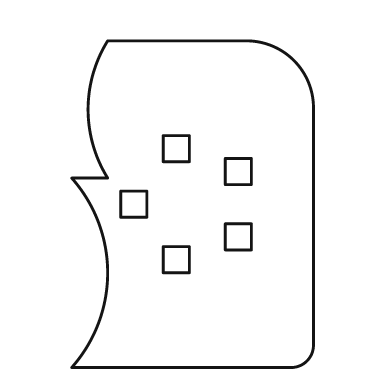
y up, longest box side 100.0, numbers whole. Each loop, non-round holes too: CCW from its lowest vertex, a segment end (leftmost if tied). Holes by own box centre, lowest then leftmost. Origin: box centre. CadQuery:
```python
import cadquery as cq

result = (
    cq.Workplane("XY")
    .moveTo(-37.0, -50.0)
    .lineTo(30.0, -50.0)
    .threePointArc((35.0, -48.0), (37.0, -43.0))
    .lineTo(37.0, 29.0)
    .threePointArc((31.0, 44.0), (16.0, 50.0))
    .lineTo(-26.0, 50.0)
    .threePointArc((-32.0, 29.0), (-26.0, 8.0))
    .lineTo(-37.0, 8.0)
    .threePointArc((-26.0, -21.0), (-37.0, -50.0))
    .close()
    .moveTo(-9.0, -21.0)
    .lineTo(-1.0, -21.0)
    .lineTo(-1.0, -13.0)
    .lineTo(-9.0, -13.0)
    .close()
    .moveTo(10.0, -14.0)
    .lineTo(18.0, -14.0)
    .lineTo(18.0, -6.0)
    .lineTo(10.0, -6.0)
    .close()
    .moveTo(-22.0, -4.0)
    .lineTo(-14.0, -4.0)
    .lineTo(-14.0, 4.0)
    .lineTo(-22.0, 4.0)
    .close()
    .moveTo(10.0, 6.0)
    .lineTo(18.0, 6.0)
    .lineTo(18.0, 14.0)
    .lineTo(10.0, 14.0)
    .close()
    .moveTo(-9.0, 13.0)
    .lineTo(-1.0, 13.0)
    .lineTo(-1.0, 21.0)
    .lineTo(-9.0, 21.0)
    .close()
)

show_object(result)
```